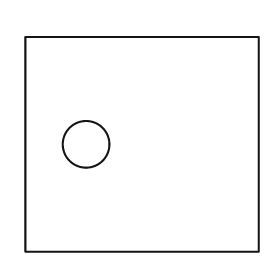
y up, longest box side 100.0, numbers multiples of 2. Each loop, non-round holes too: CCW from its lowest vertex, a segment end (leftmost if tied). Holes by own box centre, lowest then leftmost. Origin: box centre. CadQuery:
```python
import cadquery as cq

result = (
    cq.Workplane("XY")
    .moveTo(-50.0, -46.0)
    .lineTo(50.0, -46.0)
    .lineTo(50.0, 46.0)
    .lineTo(-50.0, 46.0)
    .close()
    .moveTo(-24.0, 0.0)
    .circle(10.0)
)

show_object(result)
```